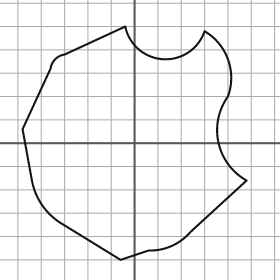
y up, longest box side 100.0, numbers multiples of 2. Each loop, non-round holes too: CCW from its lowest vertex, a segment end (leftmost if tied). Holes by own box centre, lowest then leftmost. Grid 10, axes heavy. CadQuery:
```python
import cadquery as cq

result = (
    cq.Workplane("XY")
    .moveTo(-6.0, -50.0)
    .lineTo(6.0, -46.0)
    .threePointArc((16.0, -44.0), (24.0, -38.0))
    .lineTo(48.0, -16.0)
    .threePointArc((36.0, 0.0), (40.0, 20.0))
    .threePointArc((40.0, 36.0), (30.0, 48.0))
    .threePointArc((12.0, 36.0), (-4.0, 50.0))
    .lineTo(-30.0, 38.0)
    .threePointArc((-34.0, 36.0), (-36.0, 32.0))
    .lineTo(-48.0, 6.0)
    .lineTo(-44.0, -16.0)
    .threePointArc((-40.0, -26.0), (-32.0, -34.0))
    .close()
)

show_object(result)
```